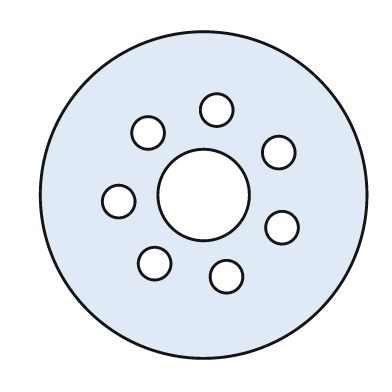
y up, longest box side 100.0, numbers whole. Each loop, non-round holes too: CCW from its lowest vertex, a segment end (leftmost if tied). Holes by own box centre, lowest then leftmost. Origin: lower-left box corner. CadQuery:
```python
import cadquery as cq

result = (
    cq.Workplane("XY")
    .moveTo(50.0, 50.0)
    .circle(50.0)
    .moveTo(57.0, 25.0)
    .circle(5.0)
    .moveTo(35.0, 29.0)
    .circle(5.0)
    .moveTo(74.0, 40.0)
    .circle(5.0)
    .moveTo(24.0, 48.0)
    .circle(5.0)
    .moveTo(50.0, 50.0)
    .circle(14.0)
    .moveTo(73.0, 63.0)
    .circle(5.0)
    .moveTo(33.0, 69.0)
    .circle(5.0)
    .moveTo(54.0, 76.0)
    .circle(5.0)
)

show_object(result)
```